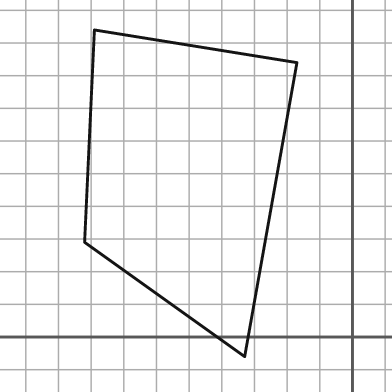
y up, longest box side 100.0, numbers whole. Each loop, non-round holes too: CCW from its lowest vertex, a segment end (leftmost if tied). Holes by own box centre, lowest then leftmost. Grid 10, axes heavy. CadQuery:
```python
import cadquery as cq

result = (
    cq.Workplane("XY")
    .moveTo(-33.0, -6.0)
    .lineTo(-17.0, 84.0)
    .lineTo(-79.0, 94.0)
    .lineTo(-82.0, 29.0)
    .close()
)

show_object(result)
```